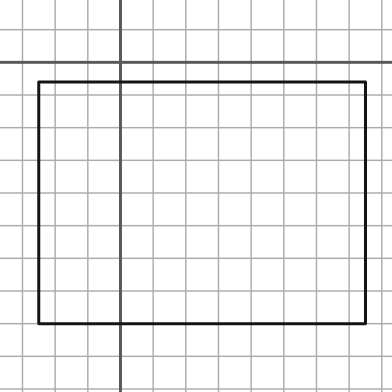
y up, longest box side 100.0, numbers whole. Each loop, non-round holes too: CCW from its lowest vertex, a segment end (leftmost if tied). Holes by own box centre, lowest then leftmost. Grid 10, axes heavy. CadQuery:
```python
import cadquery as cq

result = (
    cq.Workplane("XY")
    .moveTo(-25.0, -80.0)
    .lineTo(75.0, -80.0)
    .lineTo(75.0, -6.0)
    .lineTo(-25.0, -6.0)
    .close()
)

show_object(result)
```